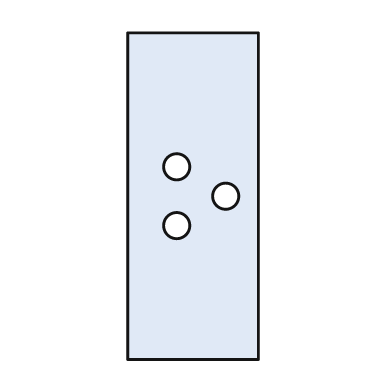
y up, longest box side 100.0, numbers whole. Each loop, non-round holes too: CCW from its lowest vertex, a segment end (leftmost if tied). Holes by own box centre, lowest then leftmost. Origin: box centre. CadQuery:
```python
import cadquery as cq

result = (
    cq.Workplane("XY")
    .moveTo(-20.0, -50.0)
    .lineTo(20.0, -50.0)
    .lineTo(20.0, 50.0)
    .lineTo(-20.0, 50.0)
    .close()
    .moveTo(-5.0, -9.0)
    .circle(4.0)
    .moveTo(10.0, 0.0)
    .circle(4.0)
    .moveTo(-5.0, 9.0)
    .circle(4.0)
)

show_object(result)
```